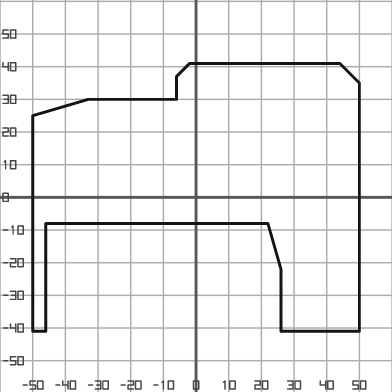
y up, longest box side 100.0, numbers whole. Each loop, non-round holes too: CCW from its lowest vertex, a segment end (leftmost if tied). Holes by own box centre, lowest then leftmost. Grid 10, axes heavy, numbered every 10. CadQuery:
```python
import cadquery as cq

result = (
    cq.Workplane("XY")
    .moveTo(-50.0, -41.0)
    .lineTo(-46.0, -41.0)
    .lineTo(-46.0, -8.0)
    .lineTo(22.0, -8.0)
    .lineTo(26.0, -22.0)
    .lineTo(26.0, -41.0)
    .lineTo(50.0, -41.0)
    .lineTo(50.0, 35.0)
    .lineTo(44.0, 41.0)
    .lineTo(-2.0, 41.0)
    .lineTo(-6.0, 37.0)
    .lineTo(-6.0, 30.0)
    .lineTo(-33.0, 30.0)
    .lineTo(-50.0, 25.0)
    .close()
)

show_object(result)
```